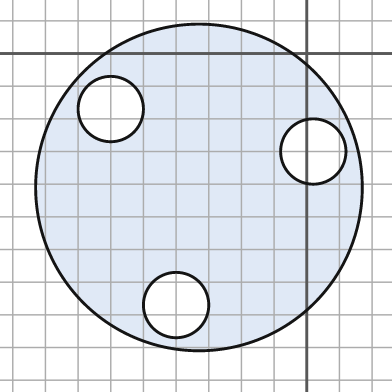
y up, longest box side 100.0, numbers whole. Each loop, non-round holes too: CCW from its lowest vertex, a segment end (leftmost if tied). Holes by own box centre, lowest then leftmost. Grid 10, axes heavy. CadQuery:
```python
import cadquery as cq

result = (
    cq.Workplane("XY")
    .moveTo(-33.0, -41.0)
    .circle(50.0)
    .moveTo(-40.0, -77.0)
    .circle(10.0)
    .moveTo(2.0, -30.0)
    .circle(10.0)
    .moveTo(-60.0, -17.0)
    .circle(10.0)
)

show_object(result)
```